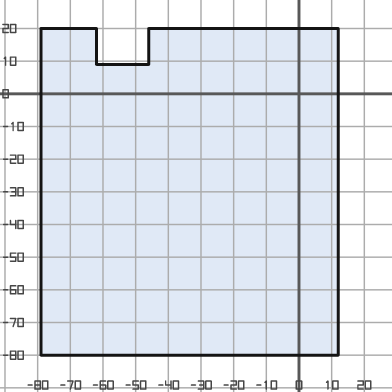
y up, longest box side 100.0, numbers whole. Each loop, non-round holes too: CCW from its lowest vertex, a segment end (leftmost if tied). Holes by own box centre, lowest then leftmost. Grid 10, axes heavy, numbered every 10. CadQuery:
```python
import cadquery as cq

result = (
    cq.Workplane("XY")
    .moveTo(-79.0, -80.0)
    .lineTo(12.0, -80.0)
    .lineTo(12.0, 20.0)
    .lineTo(-46.0, 20.0)
    .lineTo(-46.0, 9.0)
    .lineTo(-62.0, 9.0)
    .lineTo(-62.0, 20.0)
    .lineTo(-79.0, 20.0)
    .close()
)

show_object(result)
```